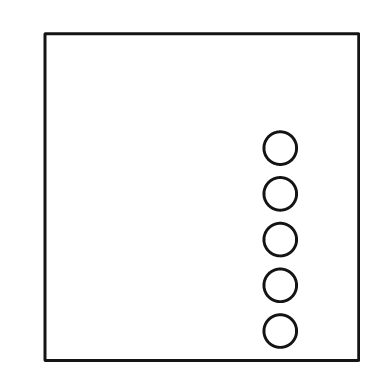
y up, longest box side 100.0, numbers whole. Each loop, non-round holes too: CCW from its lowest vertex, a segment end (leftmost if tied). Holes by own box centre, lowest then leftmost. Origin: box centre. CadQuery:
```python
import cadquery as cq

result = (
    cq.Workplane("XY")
    .moveTo(-48.0, -50.0)
    .lineTo(48.0, -50.0)
    .lineTo(48.0, 50.0)
    .lineTo(-48.0, 50.0)
    .close()
    .moveTo(24.0, -41.0)
    .circle(5.0)
    .moveTo(24.0, -27.0)
    .circle(5.0)
    .moveTo(24.0, -13.0)
    .circle(5.0)
    .moveTo(24.0, 1.0)
    .circle(5.0)
    .moveTo(24.0, 15.0)
    .circle(5.0)
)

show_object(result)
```